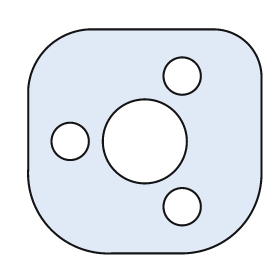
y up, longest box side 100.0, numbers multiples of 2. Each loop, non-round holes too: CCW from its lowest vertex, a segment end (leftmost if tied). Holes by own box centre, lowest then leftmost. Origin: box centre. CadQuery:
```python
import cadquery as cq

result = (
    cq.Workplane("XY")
    .moveTo(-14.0, -48.0)
    .lineTo(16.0, -48.0)
    .threePointArc((40.0, -38.0), (50.0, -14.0))
    .lineTo(50.0, 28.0)
    .threePointArc((44.0, 42.0), (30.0, 48.0))
    .lineTo(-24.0, 48.0)
    .threePointArc((-42.0, 40.0), (-50.0, 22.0))
    .lineTo(-50.0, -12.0)
    .threePointArc((-40.0, -38.0), (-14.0, -48.0))
    .close()
    .moveTo(16.0, -28.0)
    .circle(8.0)
    .moveTo(-32.0, 0.0)
    .circle(8.0)
    .moveTo(0.0, 0.0)
    .circle(18.0)
    .moveTo(16.0, 28.0)
    .circle(8.0)
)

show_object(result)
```